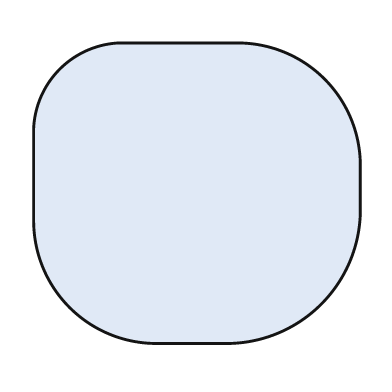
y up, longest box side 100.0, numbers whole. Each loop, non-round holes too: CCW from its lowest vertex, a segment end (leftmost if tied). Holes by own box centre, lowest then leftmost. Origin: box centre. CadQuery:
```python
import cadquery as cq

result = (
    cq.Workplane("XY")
    .moveTo(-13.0, -46.0)
    .lineTo(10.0, -46.0)
    .threePointArc((38.0, -34.0), (50.0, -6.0))
    .lineTo(50.0, 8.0)
    .threePointArc((39.0, 35.0), (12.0, 46.0))
    .lineTo(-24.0, 46.0)
    .threePointArc((-42.0, 38.0), (-50.0, 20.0))
    .lineTo(-50.0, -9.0)
    .threePointArc((-39.0, -35.0), (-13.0, -46.0))
    .close()
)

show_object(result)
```